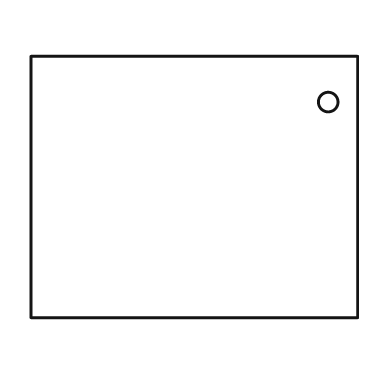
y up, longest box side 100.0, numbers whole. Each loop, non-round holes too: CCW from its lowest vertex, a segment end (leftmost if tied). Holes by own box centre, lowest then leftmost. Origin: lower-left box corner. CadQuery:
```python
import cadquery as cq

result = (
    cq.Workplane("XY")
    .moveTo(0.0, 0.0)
    .lineTo(100.0, 0.0)
    .lineTo(100.0, 80.0)
    .lineTo(0.0, 80.0)
    .close()
    .moveTo(91.0, 66.0)
    .circle(3.0)
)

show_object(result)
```